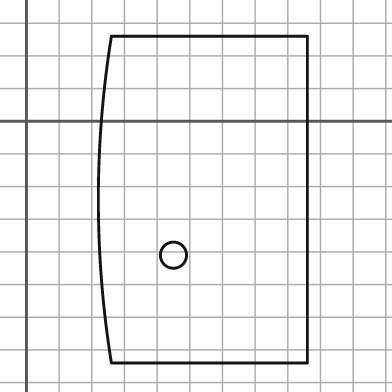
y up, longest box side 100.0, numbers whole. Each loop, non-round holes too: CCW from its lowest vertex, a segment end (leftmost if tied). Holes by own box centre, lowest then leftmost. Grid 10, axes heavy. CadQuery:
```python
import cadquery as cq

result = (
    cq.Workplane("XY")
    .moveTo(26.0, -74.0)
    .lineTo(86.0, -74.0)
    .lineTo(86.0, 26.0)
    .lineTo(26.0, 26.0)
    .threePointArc((22.0, -24.0), (26.0, -74.0))
    .close()
    .moveTo(45.0, -41.0)
    .circle(4.0)
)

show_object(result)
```